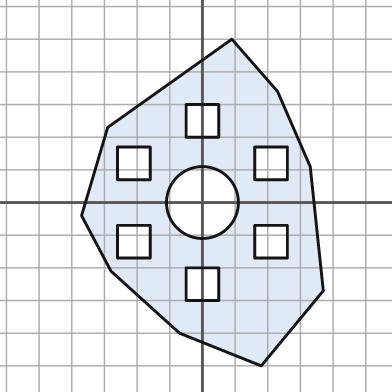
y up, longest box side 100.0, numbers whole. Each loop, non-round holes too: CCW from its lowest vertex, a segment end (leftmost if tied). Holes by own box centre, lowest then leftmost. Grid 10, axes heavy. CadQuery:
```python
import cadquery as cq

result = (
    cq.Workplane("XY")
    .moveTo(18.0, -50.0)
    .lineTo(37.0, -27.0)
    .lineTo(33.0, 11.0)
    .lineTo(23.0, 34.0)
    .lineTo(9.0, 50.0)
    .lineTo(-29.0, 23.0)
    .lineTo(-37.0, -4.0)
    .lineTo(-28.0, -21.0)
    .lineTo(-7.0, -40.0)
    .close()
    .moveTo(-5.0, -30.0)
    .lineTo(5.0, -30.0)
    .lineTo(5.0, -20.0)
    .lineTo(-5.0, -20.0)
    .close()
    .moveTo(-26.0, -17.0)
    .lineTo(-16.0, -17.0)
    .lineTo(-16.0, -7.0)
    .lineTo(-26.0, -7.0)
    .close()
    .moveTo(16.0, -17.0)
    .lineTo(26.0, -17.0)
    .lineTo(26.0, -7.0)
    .lineTo(16.0, -7.0)
    .close()
    .moveTo(0.0, 0.0)
    .circle(11.0)
    .moveTo(-26.0, 7.0)
    .lineTo(-16.0, 7.0)
    .lineTo(-16.0, 17.0)
    .lineTo(-26.0, 17.0)
    .close()
    .moveTo(16.0, 7.0)
    .lineTo(26.0, 7.0)
    .lineTo(26.0, 17.0)
    .lineTo(16.0, 17.0)
    .close()
    .moveTo(-5.0, 20.0)
    .lineTo(5.0, 20.0)
    .lineTo(5.0, 30.0)
    .lineTo(-5.0, 30.0)
    .close()
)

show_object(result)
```